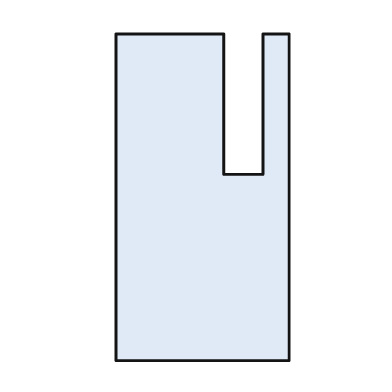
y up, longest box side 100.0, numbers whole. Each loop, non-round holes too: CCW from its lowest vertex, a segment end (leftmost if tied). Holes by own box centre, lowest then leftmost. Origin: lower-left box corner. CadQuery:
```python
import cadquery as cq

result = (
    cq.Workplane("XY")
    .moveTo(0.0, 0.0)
    .lineTo(53.0, 0.0)
    .lineTo(53.0, 100.0)
    .lineTo(45.0, 100.0)
    .lineTo(45.0, 57.0)
    .lineTo(33.0, 57.0)
    .lineTo(33.0, 100.0)
    .lineTo(0.0, 100.0)
    .close()
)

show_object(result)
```